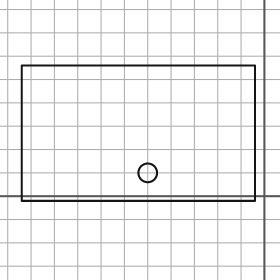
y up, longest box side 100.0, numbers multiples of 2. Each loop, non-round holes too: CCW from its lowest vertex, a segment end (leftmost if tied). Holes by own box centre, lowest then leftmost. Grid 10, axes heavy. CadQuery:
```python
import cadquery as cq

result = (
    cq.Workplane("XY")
    .moveTo(-104.0, -2.0)
    .lineTo(-4.0, -2.0)
    .lineTo(-4.0, 56.0)
    .lineTo(-104.0, 56.0)
    .close()
    .moveTo(-50.0, 10.0)
    .circle(4.0)
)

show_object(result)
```